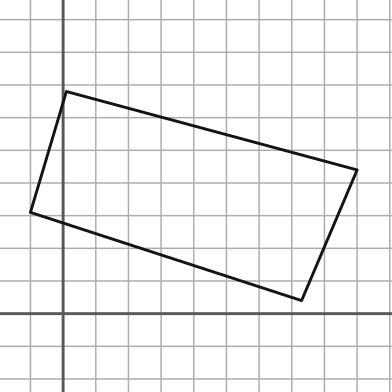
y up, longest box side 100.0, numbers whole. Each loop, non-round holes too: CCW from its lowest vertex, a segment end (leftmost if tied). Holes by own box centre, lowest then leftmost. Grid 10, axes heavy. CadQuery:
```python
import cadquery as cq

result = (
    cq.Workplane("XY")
    .moveTo(73.0, 4.0)
    .lineTo(90.0, 44.0)
    .lineTo(1.0, 68.0)
    .lineTo(-10.0, 31.0)
    .close()
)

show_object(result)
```